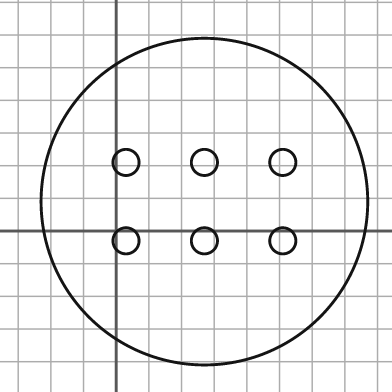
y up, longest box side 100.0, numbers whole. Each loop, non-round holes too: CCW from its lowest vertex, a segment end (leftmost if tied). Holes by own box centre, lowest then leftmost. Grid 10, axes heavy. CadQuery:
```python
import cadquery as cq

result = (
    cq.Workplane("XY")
    .moveTo(27.0, 9.0)
    .circle(50.0)
    .moveTo(3.0, -3.0)
    .circle(4.0)
    .moveTo(27.0, -3.0)
    .circle(4.0)
    .moveTo(51.0, -3.0)
    .circle(4.0)
    .moveTo(3.0, 21.0)
    .circle(4.0)
    .moveTo(27.0, 21.0)
    .circle(4.0)
    .moveTo(51.0, 21.0)
    .circle(4.0)
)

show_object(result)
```